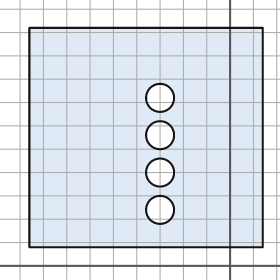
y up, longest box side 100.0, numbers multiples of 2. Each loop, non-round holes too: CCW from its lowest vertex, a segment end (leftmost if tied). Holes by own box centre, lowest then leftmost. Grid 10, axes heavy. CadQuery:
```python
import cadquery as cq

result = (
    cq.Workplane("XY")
    .moveTo(-86.0, 8.0)
    .lineTo(14.0, 8.0)
    .lineTo(14.0, 102.0)
    .lineTo(-86.0, 102.0)
    .close()
    .moveTo(-30.0, 24.0)
    .circle(6.0)
    .moveTo(-30.0, 40.0)
    .circle(6.0)
    .moveTo(-30.0, 56.0)
    .circle(6.0)
    .moveTo(-30.0, 72.0)
    .circle(6.0)
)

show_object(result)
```